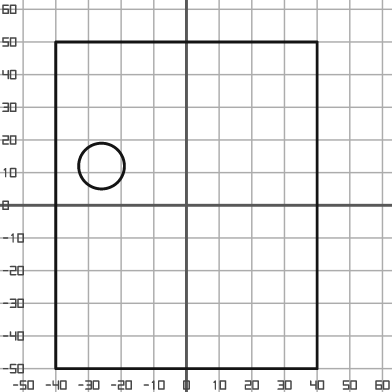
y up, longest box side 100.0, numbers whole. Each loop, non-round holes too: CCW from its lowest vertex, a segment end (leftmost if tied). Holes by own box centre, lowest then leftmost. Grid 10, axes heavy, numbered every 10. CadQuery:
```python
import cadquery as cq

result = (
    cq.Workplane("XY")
    .moveTo(-40.0, -50.0)
    .lineTo(40.0, -50.0)
    .lineTo(40.0, 50.0)
    .lineTo(-40.0, 50.0)
    .close()
    .moveTo(-26.0, 12.0)
    .circle(7.0)
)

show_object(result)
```